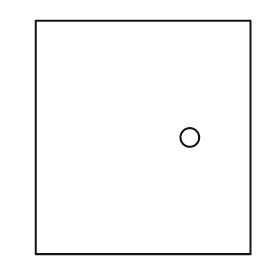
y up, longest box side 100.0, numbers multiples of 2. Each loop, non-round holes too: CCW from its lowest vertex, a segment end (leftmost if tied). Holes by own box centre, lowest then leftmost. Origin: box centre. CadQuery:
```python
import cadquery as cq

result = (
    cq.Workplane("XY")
    .moveTo(-46.0, -50.0)
    .lineTo(46.0, -50.0)
    .lineTo(46.0, 50.0)
    .lineTo(-46.0, 50.0)
    .close()
    .moveTo(20.0, 0.0)
    .circle(4.0)
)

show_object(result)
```